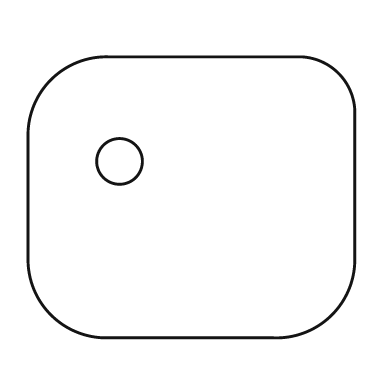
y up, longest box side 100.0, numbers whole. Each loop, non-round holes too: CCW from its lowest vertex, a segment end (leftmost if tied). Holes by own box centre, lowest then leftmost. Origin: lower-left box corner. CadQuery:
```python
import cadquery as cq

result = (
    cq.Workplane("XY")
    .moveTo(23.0, 0.0)
    .lineTo(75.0, 0.0)
    .threePointArc((93.0, 7.0), (100.0, 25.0))
    .lineTo(100.0, 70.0)
    .threePointArc((95.0, 81.0), (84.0, 86.0))
    .lineTo(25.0, 86.0)
    .threePointArc((7.0, 79.0), (0.0, 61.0))
    .lineTo(0.0, 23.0)
    .threePointArc((7.0, 7.0), (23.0, 0.0))
    .close()
    .moveTo(28.0, 54.0)
    .circle(7.0)
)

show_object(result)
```